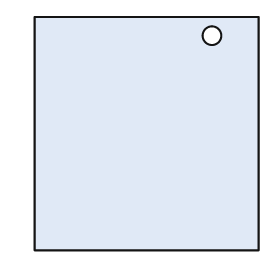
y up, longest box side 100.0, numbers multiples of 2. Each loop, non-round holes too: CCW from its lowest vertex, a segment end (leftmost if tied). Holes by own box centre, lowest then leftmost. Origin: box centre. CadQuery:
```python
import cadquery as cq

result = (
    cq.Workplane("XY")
    .moveTo(-48.0, -50.0)
    .lineTo(48.0, -50.0)
    .lineTo(48.0, 50.0)
    .lineTo(-48.0, 50.0)
    .close()
    .moveTo(28.0, 42.0)
    .circle(4.0)
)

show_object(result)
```